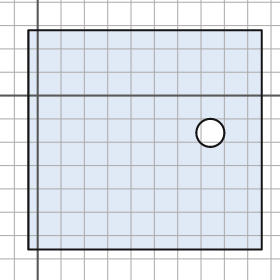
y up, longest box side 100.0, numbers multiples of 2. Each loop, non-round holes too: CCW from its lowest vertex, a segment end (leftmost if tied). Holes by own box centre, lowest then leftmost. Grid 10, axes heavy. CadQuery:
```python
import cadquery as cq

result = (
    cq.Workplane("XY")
    .moveTo(-4.0, -66.0)
    .lineTo(96.0, -66.0)
    .lineTo(96.0, 28.0)
    .lineTo(-4.0, 28.0)
    .close()
    .moveTo(74.0, -16.0)
    .circle(6.0)
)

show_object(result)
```